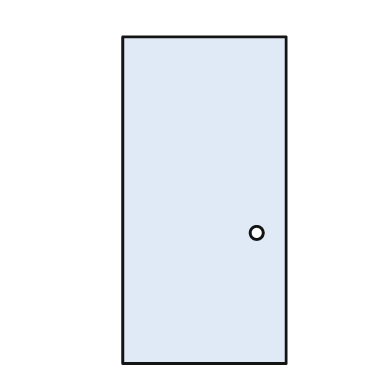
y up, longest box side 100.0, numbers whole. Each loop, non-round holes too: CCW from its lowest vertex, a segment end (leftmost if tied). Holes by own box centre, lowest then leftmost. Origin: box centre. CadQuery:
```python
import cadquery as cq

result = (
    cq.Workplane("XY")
    .moveTo(-25.0, -50.0)
    .lineTo(25.0, -50.0)
    .lineTo(25.0, 50.0)
    .lineTo(-25.0, 50.0)
    .close()
    .moveTo(16.0, -10.0)
    .circle(2.0)
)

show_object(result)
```